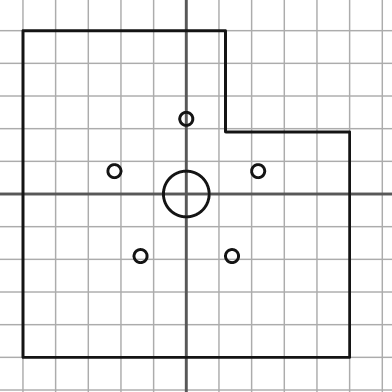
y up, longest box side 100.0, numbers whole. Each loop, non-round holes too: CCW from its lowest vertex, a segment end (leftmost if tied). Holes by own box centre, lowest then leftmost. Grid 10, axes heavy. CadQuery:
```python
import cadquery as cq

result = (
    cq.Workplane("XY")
    .moveTo(-50.0, -50.0)
    .lineTo(50.0, -50.0)
    .lineTo(50.0, 19.0)
    .lineTo(12.0, 19.0)
    .lineTo(12.0, 50.0)
    .lineTo(-50.0, 50.0)
    .close()
    .moveTo(-14.0, -19.0)
    .circle(2.0)
    .moveTo(14.0, -19.0)
    .circle(2.0)
    .moveTo(0.0, 0.0)
    .circle(7.0)
    .moveTo(-22.0, 7.0)
    .circle(2.0)
    .moveTo(22.0, 7.0)
    .circle(2.0)
    .moveTo(0.0, 23.0)
    .circle(2.0)
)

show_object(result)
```